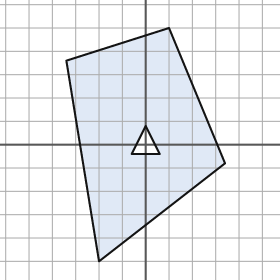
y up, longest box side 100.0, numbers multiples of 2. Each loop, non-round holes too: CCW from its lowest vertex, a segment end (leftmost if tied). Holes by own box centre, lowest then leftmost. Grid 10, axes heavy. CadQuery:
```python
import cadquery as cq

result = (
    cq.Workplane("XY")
    .moveTo(-20.0, -50.0)
    .lineTo(34.0, -8.0)
    .lineTo(10.0, 50.0)
    .lineTo(-34.0, 36.0)
    .close()
    .moveTo(-6.0, -4.0)
    .lineTo(6.0, -4.0)
    .lineTo(0.0, 8.0)
    .close()
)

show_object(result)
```